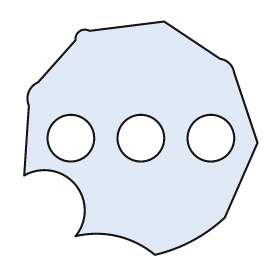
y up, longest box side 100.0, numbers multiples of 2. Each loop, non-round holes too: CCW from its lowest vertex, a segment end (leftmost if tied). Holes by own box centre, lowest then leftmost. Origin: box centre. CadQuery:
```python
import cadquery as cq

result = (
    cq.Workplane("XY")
    .moveTo(6.0, -50.0)
    .threePointArc((22.0, -44.0), (36.0, -34.0))
    .lineTo(50.0, -2.0)
    .lineTo(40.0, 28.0)
    .threePointArc((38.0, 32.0), (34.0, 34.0))
    .lineTo(10.0, 50.0)
    .lineTo(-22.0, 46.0)
    .threePointArc((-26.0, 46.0), (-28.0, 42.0))
    .lineTo(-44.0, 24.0)
    .threePointArc((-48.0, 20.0), (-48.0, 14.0))
    .lineTo(-50.0, -16.0)
    .threePointArc((-28.0, -20.0), (-28.0, -42.0))
    .threePointArc((-10.0, -42.0), (6.0, -50.0))
    .close()
    .moveTo(-30.0, 0.0)
    .circle(10.0)
    .moveTo(0.0, 0.0)
    .circle(10.0)
    .moveTo(30.0, 0.0)
    .circle(10.0)
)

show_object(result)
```